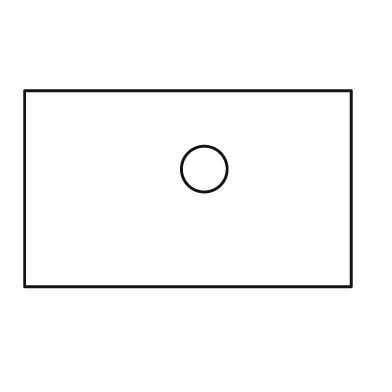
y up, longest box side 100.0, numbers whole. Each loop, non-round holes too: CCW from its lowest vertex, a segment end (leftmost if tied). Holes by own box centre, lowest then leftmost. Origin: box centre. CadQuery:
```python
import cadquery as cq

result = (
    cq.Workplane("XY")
    .moveTo(-50.0, -30.0)
    .lineTo(50.0, -30.0)
    .lineTo(50.0, 30.0)
    .lineTo(-50.0, 30.0)
    .close()
    .moveTo(5.0, 6.0)
    .circle(7.0)
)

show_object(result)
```